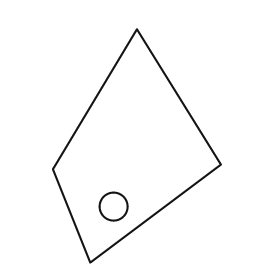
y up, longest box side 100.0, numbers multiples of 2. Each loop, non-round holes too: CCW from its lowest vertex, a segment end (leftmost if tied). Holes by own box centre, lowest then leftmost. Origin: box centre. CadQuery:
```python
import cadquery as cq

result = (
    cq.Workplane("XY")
    .moveTo(-20.0, -50.0)
    .lineTo(36.0, -8.0)
    .lineTo(0.0, 50.0)
    .lineTo(-36.0, -10.0)
    .close()
    .moveTo(-10.0, -26.0)
    .circle(6.0)
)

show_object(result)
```